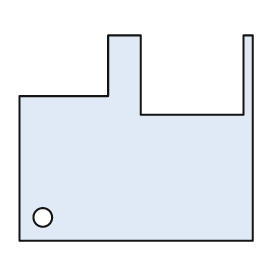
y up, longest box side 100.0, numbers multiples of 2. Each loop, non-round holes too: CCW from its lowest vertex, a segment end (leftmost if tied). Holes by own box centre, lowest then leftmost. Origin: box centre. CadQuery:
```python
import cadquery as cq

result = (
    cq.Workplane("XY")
    .moveTo(-50.0, -44.0)
    .lineTo(50.0, -44.0)
    .lineTo(50.0, 44.0)
    .lineTo(46.0, 44.0)
    .lineTo(46.0, 10.0)
    .lineTo(2.0, 10.0)
    .lineTo(2.0, 44.0)
    .lineTo(-12.0, 44.0)
    .lineTo(-12.0, 18.0)
    .lineTo(-50.0, 18.0)
    .close()
    .moveTo(-40.0, -34.0)
    .circle(4.0)
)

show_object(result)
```